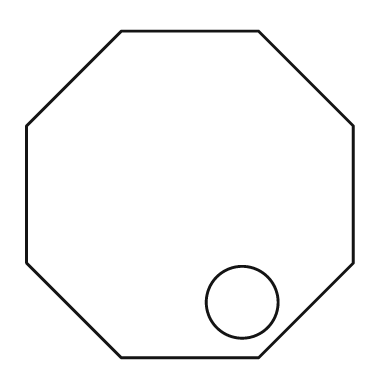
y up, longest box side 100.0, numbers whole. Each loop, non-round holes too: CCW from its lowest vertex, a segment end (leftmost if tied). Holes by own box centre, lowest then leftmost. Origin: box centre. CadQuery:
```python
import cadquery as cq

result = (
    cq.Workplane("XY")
    .moveTo(-21.0, -50.0)
    .lineTo(21.0, -50.0)
    .lineTo(50.0, -21.0)
    .lineTo(50.0, 21.0)
    .lineTo(21.0, 50.0)
    .lineTo(-21.0, 50.0)
    .lineTo(-50.0, 21.0)
    .lineTo(-50.0, -21.0)
    .close()
    .moveTo(16.0, -33.0)
    .circle(11.0)
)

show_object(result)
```